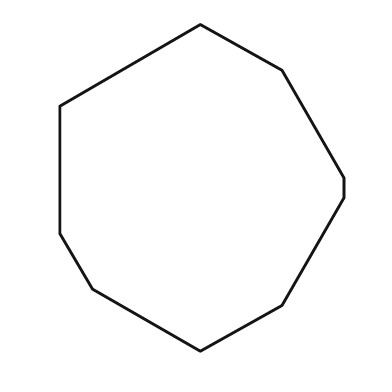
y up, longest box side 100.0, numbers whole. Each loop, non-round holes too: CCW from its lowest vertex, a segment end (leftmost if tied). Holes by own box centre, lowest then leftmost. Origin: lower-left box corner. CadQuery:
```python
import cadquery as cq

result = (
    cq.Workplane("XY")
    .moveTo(43.0, 0.0)
    .lineTo(68.0, 14.0)
    .lineTo(87.0, 47.0)
    .lineTo(87.0, 53.0)
    .lineTo(68.0, 86.0)
    .lineTo(43.0, 100.0)
    .lineTo(0.0, 75.0)
    .lineTo(0.0, 36.0)
    .lineTo(10.0, 19.0)
    .close()
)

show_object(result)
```